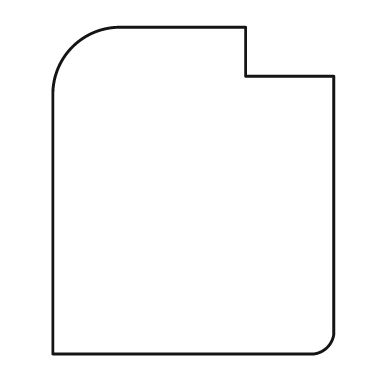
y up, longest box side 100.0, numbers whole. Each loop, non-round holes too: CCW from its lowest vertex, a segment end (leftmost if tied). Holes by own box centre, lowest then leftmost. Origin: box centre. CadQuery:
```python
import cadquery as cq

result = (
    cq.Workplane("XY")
    .moveTo(-43.0, -50.0)
    .lineTo(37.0, -50.0)
    .threePointArc((41.0, -48.0), (43.0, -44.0))
    .lineTo(43.0, 35.0)
    .lineTo(16.0, 35.0)
    .lineTo(16.0, 50.0)
    .lineTo(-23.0, 50.0)
    .threePointArc((-37.0, 44.0), (-43.0, 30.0))
    .close()
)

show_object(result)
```